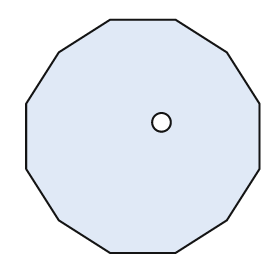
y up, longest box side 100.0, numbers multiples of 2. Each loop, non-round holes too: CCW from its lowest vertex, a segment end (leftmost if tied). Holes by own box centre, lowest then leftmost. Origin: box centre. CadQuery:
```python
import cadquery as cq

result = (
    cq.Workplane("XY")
    .moveTo(-14.0, -50.0)
    .lineTo(14.0, -50.0)
    .lineTo(36.0, -36.0)
    .lineTo(50.0, -14.0)
    .lineTo(50.0, 14.0)
    .lineTo(36.0, 36.0)
    .lineTo(14.0, 50.0)
    .lineTo(-14.0, 50.0)
    .lineTo(-36.0, 36.0)
    .lineTo(-50.0, 14.0)
    .lineTo(-50.0, -14.0)
    .lineTo(-36.0, -36.0)
    .close()
    .moveTo(8.0, 6.0)
    .circle(4.0)
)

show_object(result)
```